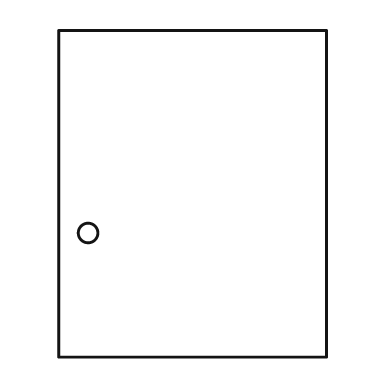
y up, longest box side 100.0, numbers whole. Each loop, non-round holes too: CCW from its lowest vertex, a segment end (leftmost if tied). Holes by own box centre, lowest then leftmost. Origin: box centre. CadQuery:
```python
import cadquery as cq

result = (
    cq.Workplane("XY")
    .moveTo(-41.0, -50.0)
    .lineTo(41.0, -50.0)
    .lineTo(41.0, 50.0)
    .lineTo(-41.0, 50.0)
    .close()
    .moveTo(-32.0, -12.0)
    .circle(3.0)
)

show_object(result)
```